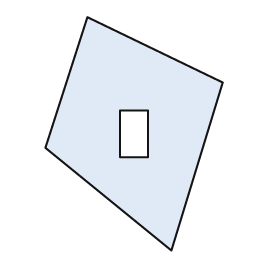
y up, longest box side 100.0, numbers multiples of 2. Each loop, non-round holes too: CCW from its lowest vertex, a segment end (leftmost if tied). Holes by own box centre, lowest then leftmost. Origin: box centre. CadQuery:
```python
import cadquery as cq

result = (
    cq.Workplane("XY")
    .moveTo(16.0, -50.0)
    .lineTo(38.0, 22.0)
    .lineTo(-20.0, 50.0)
    .lineTo(-38.0, -6.0)
    .close()
    .moveTo(-6.0, -10.0)
    .lineTo(6.0, -10.0)
    .lineTo(6.0, 10.0)
    .lineTo(-6.0, 10.0)
    .close()
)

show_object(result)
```